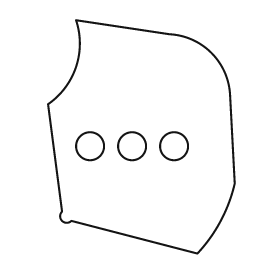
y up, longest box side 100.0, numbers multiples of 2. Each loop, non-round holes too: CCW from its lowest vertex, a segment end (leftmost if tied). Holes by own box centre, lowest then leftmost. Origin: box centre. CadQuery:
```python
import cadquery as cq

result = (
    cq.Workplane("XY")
    .moveTo(24.0, -50.0)
    .threePointArc((34.0, -36.0), (40.0, -20.0))
    .lineTo(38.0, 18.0)
    .threePointArc((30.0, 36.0), (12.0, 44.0))
    .lineTo(-28.0, 50.0)
    .threePointArc((-28.0, 30.0), (-40.0, 14.0))
    .lineTo(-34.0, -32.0)
    .threePointArc((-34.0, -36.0), (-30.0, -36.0))
    .close()
    .moveTo(-22.0, -4.0)
    .circle(6.0)
    .moveTo(-4.0, -4.0)
    .circle(6.0)
    .moveTo(14.0, -4.0)
    .circle(6.0)
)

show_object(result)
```